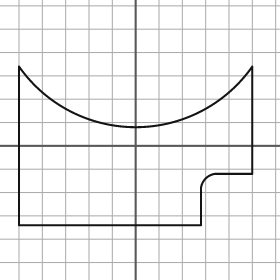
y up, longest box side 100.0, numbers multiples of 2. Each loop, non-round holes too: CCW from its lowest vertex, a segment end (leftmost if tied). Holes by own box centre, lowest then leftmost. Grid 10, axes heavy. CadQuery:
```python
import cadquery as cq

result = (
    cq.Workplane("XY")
    .moveTo(-50.0, -34.0)
    .lineTo(28.0, -34.0)
    .lineTo(28.0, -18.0)
    .threePointArc((30.0, -14.0), (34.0, -12.0))
    .lineTo(50.0, -12.0)
    .lineTo(50.0, 34.0)
    .threePointArc((0.0, 8.0), (-50.0, 34.0))
    .close()
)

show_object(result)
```